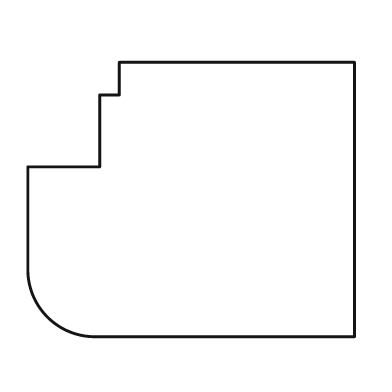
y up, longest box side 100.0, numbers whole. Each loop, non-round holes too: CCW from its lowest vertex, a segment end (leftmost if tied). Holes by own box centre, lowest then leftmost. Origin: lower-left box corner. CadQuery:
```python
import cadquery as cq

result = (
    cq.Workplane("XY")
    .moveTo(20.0, 0.0)
    .lineTo(100.0, 0.0)
    .lineTo(100.0, 84.0)
    .lineTo(28.0, 84.0)
    .lineTo(28.0, 74.0)
    .lineTo(22.0, 74.0)
    .lineTo(22.0, 52.0)
    .lineTo(0.0, 52.0)
    .lineTo(0.0, 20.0)
    .threePointArc((6.0, 6.0), (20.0, 0.0))
    .close()
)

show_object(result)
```